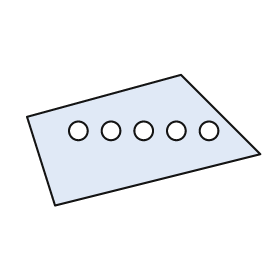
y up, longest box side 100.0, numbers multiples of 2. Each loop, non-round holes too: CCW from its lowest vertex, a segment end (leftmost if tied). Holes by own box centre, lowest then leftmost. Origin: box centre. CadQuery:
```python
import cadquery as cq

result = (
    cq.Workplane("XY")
    .moveTo(-38.0, -28.0)
    .lineTo(50.0, -6.0)
    .lineTo(16.0, 28.0)
    .lineTo(-50.0, 10.0)
    .close()
    .moveTo(-28.0, 4.0)
    .circle(4.0)
    .moveTo(-14.0, 4.0)
    .circle(4.0)
    .moveTo(0.0, 4.0)
    .circle(4.0)
    .moveTo(14.0, 4.0)
    .circle(4.0)
    .moveTo(28.0, 4.0)
    .circle(4.0)
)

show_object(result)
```